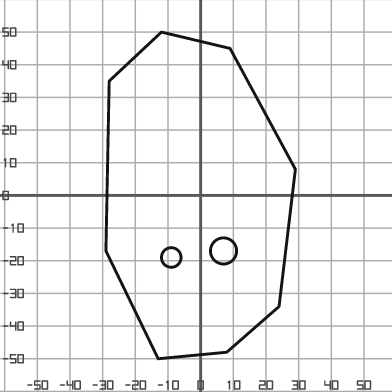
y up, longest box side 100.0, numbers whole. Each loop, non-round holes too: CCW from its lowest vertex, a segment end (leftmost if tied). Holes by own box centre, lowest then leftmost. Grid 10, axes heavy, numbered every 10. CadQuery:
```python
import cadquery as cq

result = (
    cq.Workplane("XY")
    .moveTo(-13.0, -50.0)
    .lineTo(8.0, -48.0)
    .lineTo(24.0, -34.0)
    .lineTo(29.0, 8.0)
    .lineTo(9.0, 45.0)
    .lineTo(-12.0, 50.0)
    .lineTo(-28.0, 35.0)
    .lineTo(-29.0, -17.0)
    .close()
    .moveTo(-9.0, -19.0)
    .circle(3.0)
    .moveTo(7.0, -17.0)
    .circle(4.0)
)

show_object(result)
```